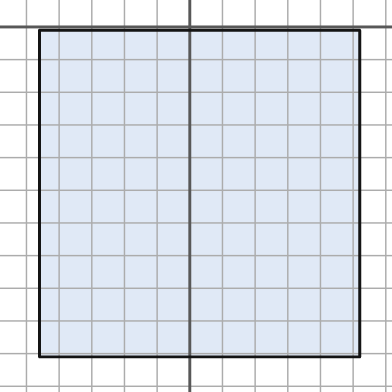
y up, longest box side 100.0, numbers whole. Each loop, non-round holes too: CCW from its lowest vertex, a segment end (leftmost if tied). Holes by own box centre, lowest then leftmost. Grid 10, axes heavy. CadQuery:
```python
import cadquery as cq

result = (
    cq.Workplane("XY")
    .moveTo(-46.0, -101.0)
    .lineTo(52.0, -101.0)
    .lineTo(52.0, -1.0)
    .lineTo(-46.0, -1.0)
    .close()
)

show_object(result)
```